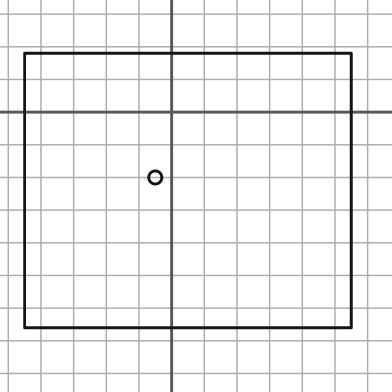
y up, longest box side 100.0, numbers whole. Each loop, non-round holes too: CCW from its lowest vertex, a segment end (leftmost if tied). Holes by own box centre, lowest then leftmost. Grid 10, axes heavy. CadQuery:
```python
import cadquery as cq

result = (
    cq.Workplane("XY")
    .moveTo(-45.0, -66.0)
    .lineTo(55.0, -66.0)
    .lineTo(55.0, 18.0)
    .lineTo(-45.0, 18.0)
    .close()
    .moveTo(-5.0, -20.0)
    .circle(2.0)
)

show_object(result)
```